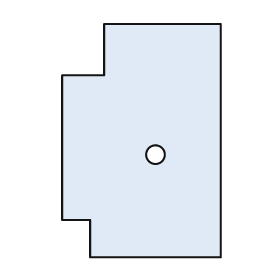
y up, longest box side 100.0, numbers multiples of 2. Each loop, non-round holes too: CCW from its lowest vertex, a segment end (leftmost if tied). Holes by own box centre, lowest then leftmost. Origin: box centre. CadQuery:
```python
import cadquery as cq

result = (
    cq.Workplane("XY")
    .moveTo(-22.0, -50.0)
    .lineTo(34.0, -50.0)
    .lineTo(34.0, 50.0)
    .lineTo(-16.0, 50.0)
    .lineTo(-16.0, 28.0)
    .lineTo(-34.0, 28.0)
    .lineTo(-34.0, -34.0)
    .lineTo(-22.0, -34.0)
    .close()
    .moveTo(6.0, -6.0)
    .circle(4.0)
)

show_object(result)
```